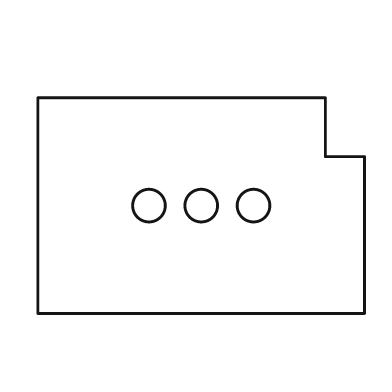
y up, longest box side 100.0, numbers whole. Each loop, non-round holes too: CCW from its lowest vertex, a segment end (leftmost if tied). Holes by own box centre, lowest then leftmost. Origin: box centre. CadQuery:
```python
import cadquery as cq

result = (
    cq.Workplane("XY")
    .moveTo(-50.0, -33.0)
    .lineTo(50.0, -33.0)
    .lineTo(50.0, 15.0)
    .lineTo(38.0, 15.0)
    .lineTo(38.0, 33.0)
    .lineTo(-50.0, 33.0)
    .close()
    .moveTo(-16.0, 0.0)
    .circle(5.0)
    .moveTo(0.0, 0.0)
    .circle(5.0)
    .moveTo(16.0, 0.0)
    .circle(5.0)
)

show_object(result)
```